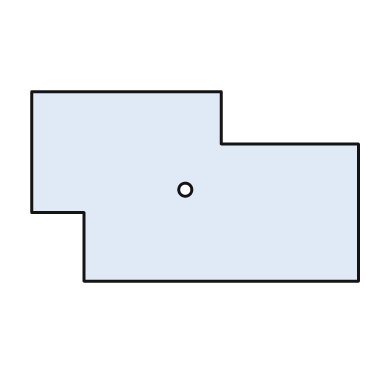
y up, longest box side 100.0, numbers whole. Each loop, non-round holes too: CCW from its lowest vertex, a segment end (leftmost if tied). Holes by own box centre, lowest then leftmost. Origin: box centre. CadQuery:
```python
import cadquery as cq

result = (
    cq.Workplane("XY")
    .moveTo(-34.0, -29.0)
    .lineTo(50.0, -29.0)
    .lineTo(50.0, 13.0)
    .lineTo(8.0, 13.0)
    .lineTo(8.0, 29.0)
    .lineTo(-50.0, 29.0)
    .lineTo(-50.0, -8.0)
    .lineTo(-34.0, -8.0)
    .close()
    .moveTo(-3.0, -1.0)
    .circle(2.0)
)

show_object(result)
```